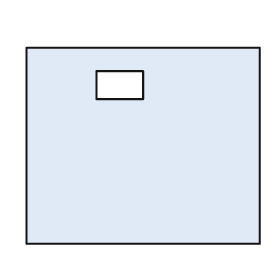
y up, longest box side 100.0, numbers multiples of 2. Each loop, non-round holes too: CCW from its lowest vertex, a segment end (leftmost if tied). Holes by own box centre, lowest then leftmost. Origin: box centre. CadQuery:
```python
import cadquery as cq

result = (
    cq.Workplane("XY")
    .moveTo(-50.0, -42.0)
    .lineTo(50.0, -42.0)
    .lineTo(50.0, 42.0)
    .lineTo(-50.0, 42.0)
    .close()
    .moveTo(-20.0, 20.0)
    .lineTo(0.0, 20.0)
    .lineTo(0.0, 32.0)
    .lineTo(-20.0, 32.0)
    .close()
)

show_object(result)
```